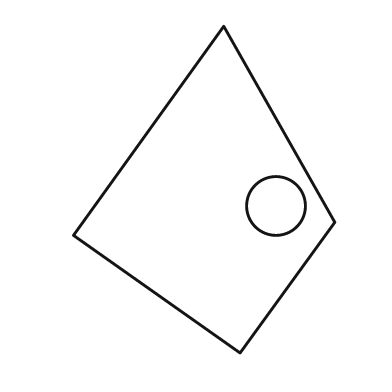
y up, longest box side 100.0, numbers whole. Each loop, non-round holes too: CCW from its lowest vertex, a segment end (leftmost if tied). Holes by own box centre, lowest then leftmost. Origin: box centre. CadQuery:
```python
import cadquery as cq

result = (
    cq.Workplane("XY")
    .moveTo(11.0, -50.0)
    .lineTo(40.0, -10.0)
    .lineTo(6.0, 50.0)
    .lineTo(-40.0, -14.0)
    .close()
    .moveTo(22.0, -5.0)
    .circle(9.0)
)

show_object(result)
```